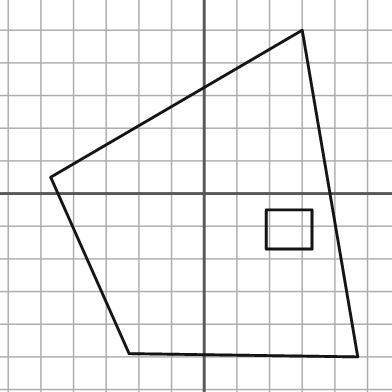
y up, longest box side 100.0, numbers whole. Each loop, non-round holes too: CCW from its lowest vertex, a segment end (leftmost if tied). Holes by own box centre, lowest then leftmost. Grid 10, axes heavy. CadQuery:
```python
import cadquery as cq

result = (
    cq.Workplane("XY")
    .moveTo(47.0, -50.0)
    .lineTo(30.0, 50.0)
    .lineTo(-47.0, 5.0)
    .lineTo(-23.0, -49.0)
    .close()
    .moveTo(19.0, -17.0)
    .lineTo(33.0, -17.0)
    .lineTo(33.0, -5.0)
    .lineTo(19.0, -5.0)
    .close()
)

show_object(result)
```